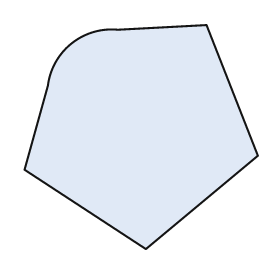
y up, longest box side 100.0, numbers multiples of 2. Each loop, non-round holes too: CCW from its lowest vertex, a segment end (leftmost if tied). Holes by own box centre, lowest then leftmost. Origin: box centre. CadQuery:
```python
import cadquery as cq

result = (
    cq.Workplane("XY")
    .moveTo(2.0, -48.0)
    .lineTo(50.0, -8.0)
    .lineTo(28.0, 48.0)
    .lineTo(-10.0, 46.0)
    .threePointArc((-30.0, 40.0), (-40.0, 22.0))
    .lineTo(-50.0, -14.0)
    .close()
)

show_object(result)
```